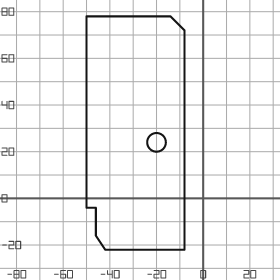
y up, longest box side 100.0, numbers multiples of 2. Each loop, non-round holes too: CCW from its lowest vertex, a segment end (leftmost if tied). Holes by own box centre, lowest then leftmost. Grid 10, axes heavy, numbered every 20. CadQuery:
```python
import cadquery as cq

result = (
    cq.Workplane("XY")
    .moveTo(-42.0, -22.0)
    .lineTo(-8.0, -22.0)
    .lineTo(-8.0, 72.0)
    .lineTo(-14.0, 78.0)
    .lineTo(-50.0, 78.0)
    .lineTo(-50.0, -4.0)
    .lineTo(-46.0, -4.0)
    .lineTo(-46.0, -16.0)
    .close()
    .moveTo(-20.0, 24.0)
    .circle(4.0)
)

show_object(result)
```